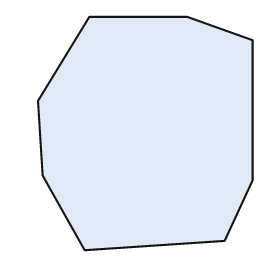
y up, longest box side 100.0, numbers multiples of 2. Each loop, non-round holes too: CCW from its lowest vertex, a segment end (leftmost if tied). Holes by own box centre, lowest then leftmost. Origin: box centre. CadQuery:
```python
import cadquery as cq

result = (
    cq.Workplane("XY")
    .moveTo(-26.0, -50.0)
    .lineTo(34.0, -46.0)
    .lineTo(46.0, -20.0)
    .lineTo(46.0, 40.0)
    .lineTo(18.0, 50.0)
    .lineTo(-24.0, 50.0)
    .lineTo(-46.0, 14.0)
    .lineTo(-44.0, -18.0)
    .close()
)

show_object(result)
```